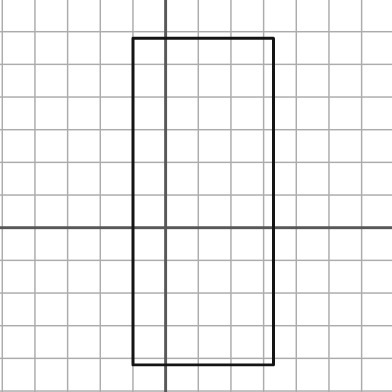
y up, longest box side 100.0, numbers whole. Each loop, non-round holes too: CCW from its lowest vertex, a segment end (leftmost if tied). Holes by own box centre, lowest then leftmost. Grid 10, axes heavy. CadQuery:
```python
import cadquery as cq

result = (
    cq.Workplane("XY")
    .moveTo(-10.0, -42.0)
    .lineTo(33.0, -42.0)
    .lineTo(33.0, 58.0)
    .lineTo(-10.0, 58.0)
    .close()
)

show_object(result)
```